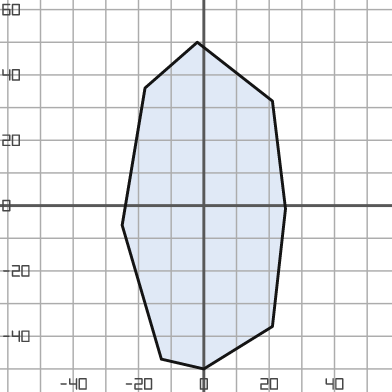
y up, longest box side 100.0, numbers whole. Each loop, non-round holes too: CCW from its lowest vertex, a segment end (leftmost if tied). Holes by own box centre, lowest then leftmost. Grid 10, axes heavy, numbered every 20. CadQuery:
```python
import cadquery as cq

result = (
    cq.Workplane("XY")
    .moveTo(0.0, -50.0)
    .lineTo(21.0, -37.0)
    .lineTo(25.0, -1.0)
    .lineTo(21.0, 32.0)
    .lineTo(-2.0, 50.0)
    .lineTo(-18.0, 36.0)
    .lineTo(-25.0, -6.0)
    .lineTo(-13.0, -47.0)
    .close()
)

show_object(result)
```